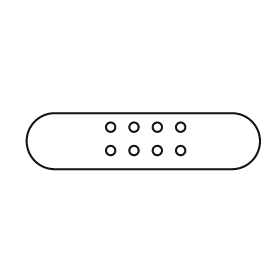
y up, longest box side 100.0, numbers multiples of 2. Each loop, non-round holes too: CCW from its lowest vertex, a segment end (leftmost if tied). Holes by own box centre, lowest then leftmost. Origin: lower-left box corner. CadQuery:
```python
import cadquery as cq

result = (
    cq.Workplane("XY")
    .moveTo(12.0, 0.0)
    .lineTo(88.0, 0.0)
    .threePointArc((100.0, 12.0), (88.0, 24.0))
    .lineTo(12.0, 24.0)
    .threePointArc((0.0, 12.0), (12.0, 0.0))
    .close()
    .moveTo(36.0, 8.0)
    .circle(2.0)
    .moveTo(46.0, 8.0)
    .circle(2.0)
    .moveTo(56.0, 8.0)
    .circle(2.0)
    .moveTo(66.0, 8.0)
    .circle(2.0)
    .moveTo(36.0, 18.0)
    .circle(2.0)
    .moveTo(46.0, 18.0)
    .circle(2.0)
    .moveTo(56.0, 18.0)
    .circle(2.0)
    .moveTo(66.0, 18.0)
    .circle(2.0)
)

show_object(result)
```